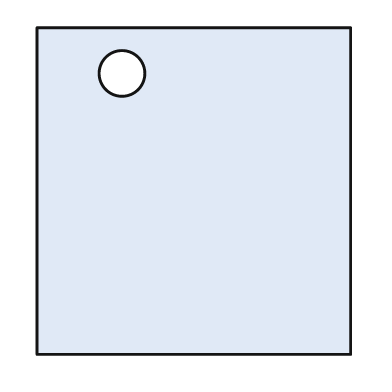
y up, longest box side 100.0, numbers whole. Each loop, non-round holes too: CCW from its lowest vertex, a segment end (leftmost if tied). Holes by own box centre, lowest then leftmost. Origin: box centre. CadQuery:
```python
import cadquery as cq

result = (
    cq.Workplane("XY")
    .moveTo(-48.0, -50.0)
    .lineTo(48.0, -50.0)
    .lineTo(48.0, 50.0)
    .lineTo(-48.0, 50.0)
    .close()
    .moveTo(-22.0, 36.0)
    .circle(7.0)
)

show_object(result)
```